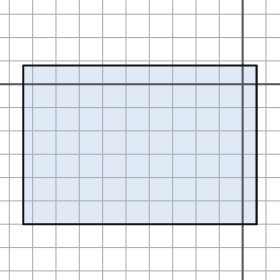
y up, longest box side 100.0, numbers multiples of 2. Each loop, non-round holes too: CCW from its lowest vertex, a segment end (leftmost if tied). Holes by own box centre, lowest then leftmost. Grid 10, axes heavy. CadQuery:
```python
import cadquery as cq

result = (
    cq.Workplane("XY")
    .moveTo(-94.0, -60.0)
    .lineTo(6.0, -60.0)
    .lineTo(6.0, 8.0)
    .lineTo(-94.0, 8.0)
    .close()
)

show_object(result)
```